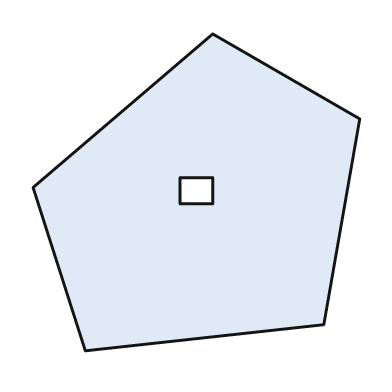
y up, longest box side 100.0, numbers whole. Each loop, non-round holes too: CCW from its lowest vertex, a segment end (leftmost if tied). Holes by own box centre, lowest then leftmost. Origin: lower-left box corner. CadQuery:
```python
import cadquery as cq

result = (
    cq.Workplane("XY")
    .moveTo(16.0, 0.0)
    .lineTo(89.0, 8.0)
    .lineTo(100.0, 71.0)
    .lineTo(55.0, 97.0)
    .lineTo(0.0, 50.0)
    .close()
    .moveTo(45.0, 45.0)
    .lineTo(55.0, 45.0)
    .lineTo(55.0, 53.0)
    .lineTo(45.0, 53.0)
    .close()
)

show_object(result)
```